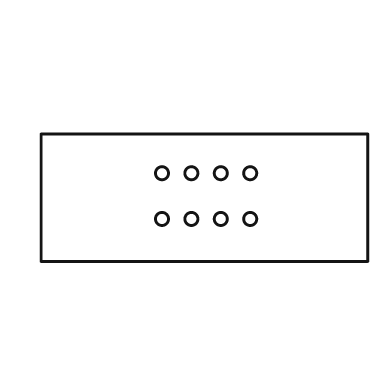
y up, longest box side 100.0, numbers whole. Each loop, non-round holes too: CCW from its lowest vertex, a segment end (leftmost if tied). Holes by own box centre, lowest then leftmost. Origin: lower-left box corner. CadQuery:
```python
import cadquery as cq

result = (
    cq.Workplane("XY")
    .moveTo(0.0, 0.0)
    .lineTo(100.0, 0.0)
    .lineTo(100.0, 39.0)
    .lineTo(0.0, 39.0)
    .close()
    .moveTo(37.0, 13.0)
    .circle(2.0)
    .moveTo(46.0, 13.0)
    .circle(2.0)
    .moveTo(55.0, 13.0)
    .circle(2.0)
    .moveTo(64.0, 13.0)
    .circle(2.0)
    .moveTo(37.0, 27.0)
    .circle(2.0)
    .moveTo(46.0, 27.0)
    .circle(2.0)
    .moveTo(55.0, 27.0)
    .circle(2.0)
    .moveTo(64.0, 27.0)
    .circle(2.0)
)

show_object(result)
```